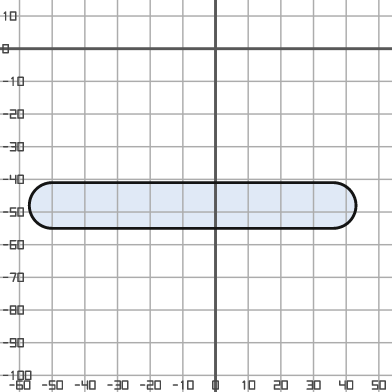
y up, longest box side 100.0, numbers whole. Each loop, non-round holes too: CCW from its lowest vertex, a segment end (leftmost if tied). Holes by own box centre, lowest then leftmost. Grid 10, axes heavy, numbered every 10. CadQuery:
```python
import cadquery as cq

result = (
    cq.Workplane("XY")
    .moveTo(-50.0, -55.0)
    .lineTo(36.0, -55.0)
    .threePointArc((43.0, -48.0), (36.0, -41.0))
    .lineTo(-50.0, -41.0)
    .threePointArc((-57.0, -48.0), (-50.0, -55.0))
    .close()
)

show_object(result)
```